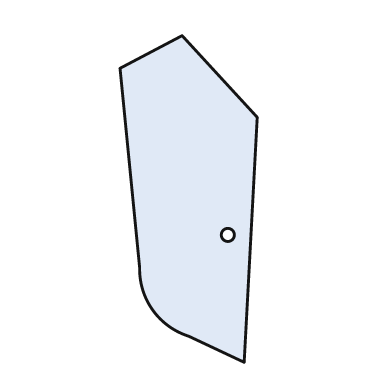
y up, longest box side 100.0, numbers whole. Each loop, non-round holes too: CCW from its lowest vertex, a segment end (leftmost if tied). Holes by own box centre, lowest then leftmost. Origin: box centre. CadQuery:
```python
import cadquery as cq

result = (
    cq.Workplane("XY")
    .moveTo(17.0, -50.0)
    .lineTo(21.0, 25.0)
    .lineTo(-2.0, 50.0)
    .lineTo(-21.0, 40.0)
    .lineTo(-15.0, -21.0)
    .threePointArc((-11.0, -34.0), (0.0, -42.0))
    .close()
    .moveTo(12.0, -11.0)
    .circle(2.0)
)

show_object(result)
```